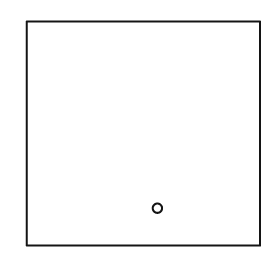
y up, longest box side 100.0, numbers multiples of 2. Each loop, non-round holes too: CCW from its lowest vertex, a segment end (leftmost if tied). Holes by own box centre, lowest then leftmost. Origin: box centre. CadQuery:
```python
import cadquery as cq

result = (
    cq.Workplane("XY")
    .moveTo(-50.0, -48.0)
    .lineTo(50.0, -48.0)
    .lineTo(50.0, 48.0)
    .lineTo(-50.0, 48.0)
    .close()
    .moveTo(6.0, -32.0)
    .circle(2.0)
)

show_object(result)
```